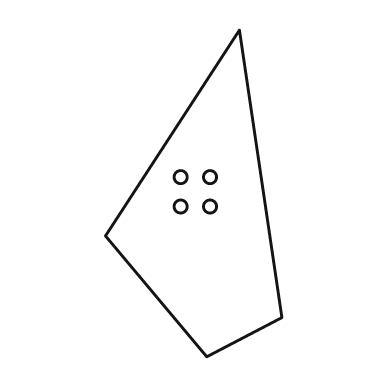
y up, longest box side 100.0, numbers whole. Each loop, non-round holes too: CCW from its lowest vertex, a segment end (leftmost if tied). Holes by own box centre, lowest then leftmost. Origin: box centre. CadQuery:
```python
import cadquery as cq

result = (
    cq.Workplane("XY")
    .moveTo(4.0, -50.0)
    .lineTo(27.0, -38.0)
    .lineTo(14.0, 50.0)
    .lineTo(-27.0, -13.0)
    .close()
    .moveTo(-4.0, -4.0)
    .circle(2.0)
    .moveTo(5.0, -4.0)
    .circle(2.0)
    .moveTo(-4.0, 5.0)
    .circle(2.0)
    .moveTo(5.0, 5.0)
    .circle(2.0)
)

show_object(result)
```